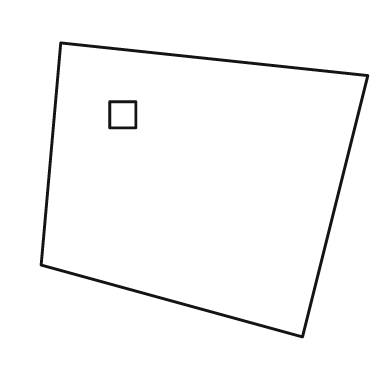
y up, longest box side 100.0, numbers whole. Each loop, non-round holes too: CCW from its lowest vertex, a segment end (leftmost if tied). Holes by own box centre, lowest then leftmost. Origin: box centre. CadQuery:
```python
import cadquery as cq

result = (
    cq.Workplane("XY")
    .moveTo(30.0, -45.0)
    .lineTo(50.0, 35.0)
    .lineTo(-44.0, 45.0)
    .lineTo(-50.0, -23.0)
    .close()
    .moveTo(-29.0, 19.0)
    .lineTo(-21.0, 19.0)
    .lineTo(-21.0, 27.0)
    .lineTo(-29.0, 27.0)
    .close()
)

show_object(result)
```